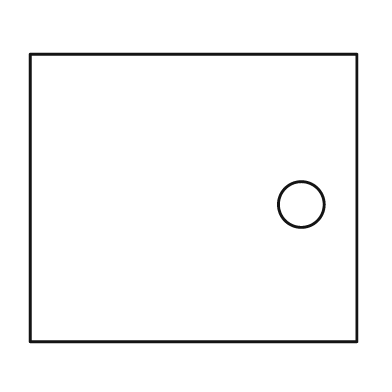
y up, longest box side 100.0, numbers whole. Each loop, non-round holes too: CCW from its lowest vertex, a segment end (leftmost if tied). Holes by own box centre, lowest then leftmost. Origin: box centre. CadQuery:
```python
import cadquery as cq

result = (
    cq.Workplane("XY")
    .moveTo(-50.0, -44.0)
    .lineTo(50.0, -44.0)
    .lineTo(50.0, 44.0)
    .lineTo(-50.0, 44.0)
    .close()
    .moveTo(33.0, -2.0)
    .circle(7.0)
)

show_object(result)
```